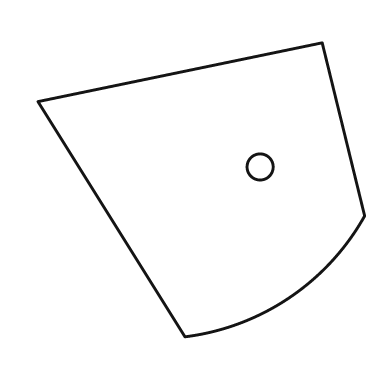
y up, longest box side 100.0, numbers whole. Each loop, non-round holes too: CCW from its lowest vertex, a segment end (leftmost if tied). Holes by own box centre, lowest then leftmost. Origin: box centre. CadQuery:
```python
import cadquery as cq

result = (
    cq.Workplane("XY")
    .moveTo(-5.0, -45.0)
    .threePointArc((27.0, -33.0), (50.0, -8.0))
    .lineTo(37.0, 45.0)
    .lineTo(-50.0, 27.0)
    .close()
    .moveTo(18.0, 7.0)
    .circle(4.0)
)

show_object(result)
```